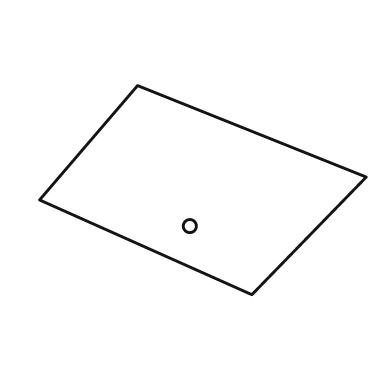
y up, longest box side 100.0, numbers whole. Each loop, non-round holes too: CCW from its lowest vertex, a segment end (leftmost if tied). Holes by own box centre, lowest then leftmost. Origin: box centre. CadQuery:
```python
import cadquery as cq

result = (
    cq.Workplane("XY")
    .moveTo(15.0, -32.0)
    .lineTo(50.0, 4.0)
    .lineTo(-20.0, 32.0)
    .lineTo(-50.0, -3.0)
    .close()
    .moveTo(-4.0, -11.0)
    .circle(2.0)
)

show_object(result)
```